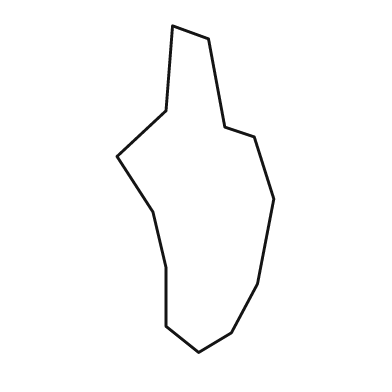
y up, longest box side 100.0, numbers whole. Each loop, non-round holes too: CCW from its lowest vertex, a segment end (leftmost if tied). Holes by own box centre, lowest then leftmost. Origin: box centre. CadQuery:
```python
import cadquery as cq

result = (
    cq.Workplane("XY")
    .moveTo(1.0, -50.0)
    .lineTo(11.0, -44.0)
    .lineTo(19.0, -29.0)
    .lineTo(24.0, -3.0)
    .lineTo(18.0, 16.0)
    .lineTo(9.0, 19.0)
    .lineTo(4.0, 46.0)
    .lineTo(-7.0, 50.0)
    .lineTo(-9.0, 24.0)
    .lineTo(-24.0, 10.0)
    .lineTo(-13.0, -7.0)
    .lineTo(-9.0, -24.0)
    .lineTo(-9.0, -42.0)
    .close()
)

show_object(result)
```